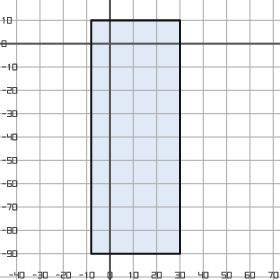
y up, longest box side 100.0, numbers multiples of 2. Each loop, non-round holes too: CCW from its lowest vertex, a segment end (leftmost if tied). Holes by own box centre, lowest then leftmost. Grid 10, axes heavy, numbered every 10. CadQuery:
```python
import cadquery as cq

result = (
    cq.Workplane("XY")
    .moveTo(-8.0, -90.0)
    .lineTo(30.0, -90.0)
    .lineTo(30.0, 10.0)
    .lineTo(-8.0, 10.0)
    .close()
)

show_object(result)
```